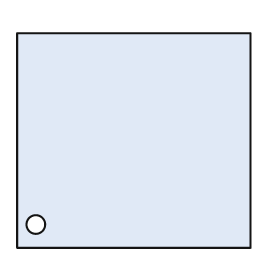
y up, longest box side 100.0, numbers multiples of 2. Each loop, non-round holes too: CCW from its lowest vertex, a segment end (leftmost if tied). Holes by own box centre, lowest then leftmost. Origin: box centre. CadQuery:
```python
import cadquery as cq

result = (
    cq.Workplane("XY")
    .moveTo(-50.0, -46.0)
    .lineTo(50.0, -46.0)
    .lineTo(50.0, 46.0)
    .lineTo(-50.0, 46.0)
    .close()
    .moveTo(-42.0, -36.0)
    .circle(4.0)
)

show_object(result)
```